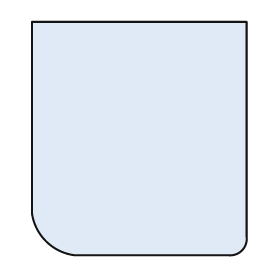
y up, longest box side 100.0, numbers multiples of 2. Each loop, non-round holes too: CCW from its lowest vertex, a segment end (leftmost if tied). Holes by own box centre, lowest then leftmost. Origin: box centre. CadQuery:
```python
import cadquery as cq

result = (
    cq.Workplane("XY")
    .moveTo(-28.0, -50.0)
    .lineTo(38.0, -50.0)
    .threePointArc((44.0, -48.0), (46.0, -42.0))
    .lineTo(46.0, 50.0)
    .lineTo(-46.0, 50.0)
    .lineTo(-46.0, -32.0)
    .threePointArc((-40.0, -44.0), (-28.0, -50.0))
    .close()
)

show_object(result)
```